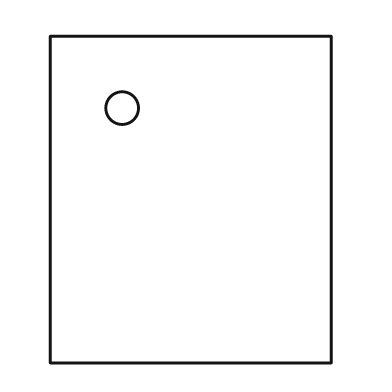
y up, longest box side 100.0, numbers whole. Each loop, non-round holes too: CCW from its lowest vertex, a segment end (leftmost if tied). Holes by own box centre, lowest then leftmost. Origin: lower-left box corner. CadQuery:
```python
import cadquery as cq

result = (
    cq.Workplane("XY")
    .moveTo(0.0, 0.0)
    .lineTo(86.0, 0.0)
    .lineTo(86.0, 100.0)
    .lineTo(0.0, 100.0)
    .close()
    .moveTo(22.0, 78.0)
    .circle(5.0)
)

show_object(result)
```